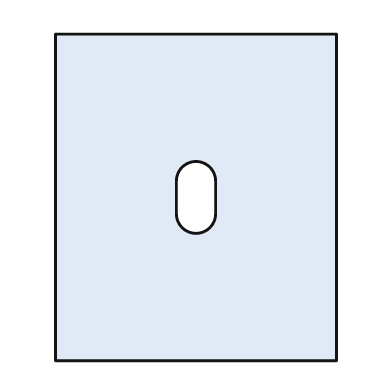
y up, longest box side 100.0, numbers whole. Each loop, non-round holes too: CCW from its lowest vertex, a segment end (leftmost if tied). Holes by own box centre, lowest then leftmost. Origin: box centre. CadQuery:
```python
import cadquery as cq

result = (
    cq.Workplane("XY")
    .moveTo(-43.0, -50.0)
    .lineTo(43.0, -50.0)
    .lineTo(43.0, 50.0)
    .lineTo(-43.0, 50.0)
    .close()
    .moveTo(-6.0, -5.0)
    .threePointArc((0.0, -11.0), (6.0, -5.0))
    .lineTo(6.0, 5.0)
    .threePointArc((0.0, 11.0), (-6.0, 5.0))
    .close()
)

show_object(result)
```